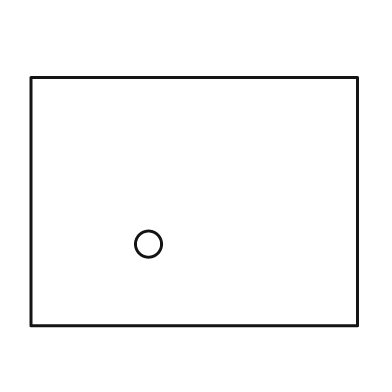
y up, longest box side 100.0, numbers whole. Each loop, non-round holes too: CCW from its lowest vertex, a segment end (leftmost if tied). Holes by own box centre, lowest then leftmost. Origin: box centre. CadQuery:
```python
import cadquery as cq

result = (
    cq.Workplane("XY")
    .moveTo(-50.0, -38.0)
    .lineTo(50.0, -38.0)
    .lineTo(50.0, 38.0)
    .lineTo(-50.0, 38.0)
    .close()
    .moveTo(-14.0, -13.0)
    .circle(4.0)
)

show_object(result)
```